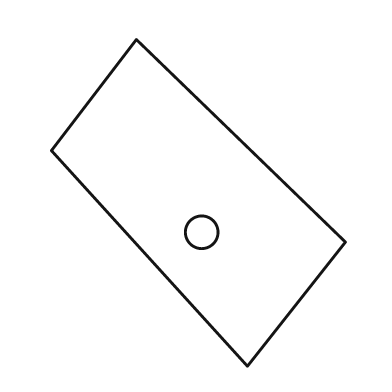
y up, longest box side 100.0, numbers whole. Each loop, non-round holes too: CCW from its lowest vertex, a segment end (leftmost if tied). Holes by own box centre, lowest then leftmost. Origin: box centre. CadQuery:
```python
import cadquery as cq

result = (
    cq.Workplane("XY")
    .moveTo(15.0, -50.0)
    .lineTo(45.0, -12.0)
    .lineTo(-19.0, 50.0)
    .lineTo(-45.0, 16.0)
    .close()
    .moveTo(1.0, -9.0)
    .circle(5.0)
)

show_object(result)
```